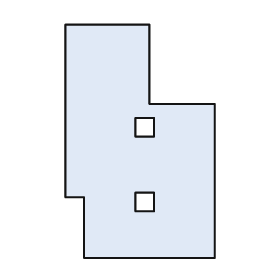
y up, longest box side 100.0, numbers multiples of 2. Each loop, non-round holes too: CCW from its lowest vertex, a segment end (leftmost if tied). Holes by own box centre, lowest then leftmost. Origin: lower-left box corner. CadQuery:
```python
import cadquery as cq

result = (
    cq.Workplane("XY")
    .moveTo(8.0, 0.0)
    .lineTo(64.0, 0.0)
    .lineTo(64.0, 66.0)
    .lineTo(36.0, 66.0)
    .lineTo(36.0, 100.0)
    .lineTo(0.0, 100.0)
    .lineTo(0.0, 26.0)
    .lineTo(8.0, 26.0)
    .close()
    .moveTo(30.0, 20.0)
    .lineTo(38.0, 20.0)
    .lineTo(38.0, 28.0)
    .lineTo(30.0, 28.0)
    .close()
    .moveTo(30.0, 52.0)
    .lineTo(38.0, 52.0)
    .lineTo(38.0, 60.0)
    .lineTo(30.0, 60.0)
    .close()
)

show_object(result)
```